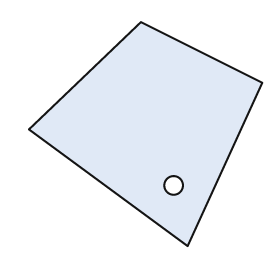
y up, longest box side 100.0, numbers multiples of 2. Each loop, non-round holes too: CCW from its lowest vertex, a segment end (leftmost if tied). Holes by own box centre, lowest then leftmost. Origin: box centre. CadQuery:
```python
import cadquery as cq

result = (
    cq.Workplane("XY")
    .moveTo(18.0, -48.0)
    .lineTo(50.0, 22.0)
    .lineTo(-2.0, 48.0)
    .lineTo(-50.0, 2.0)
    .close()
    .moveTo(12.0, -22.0)
    .circle(4.0)
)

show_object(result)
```